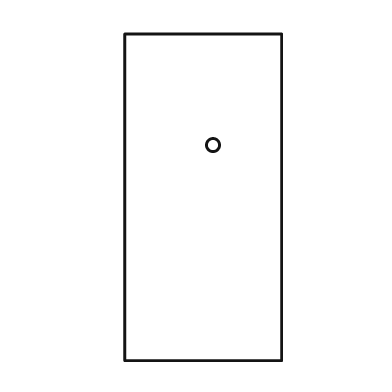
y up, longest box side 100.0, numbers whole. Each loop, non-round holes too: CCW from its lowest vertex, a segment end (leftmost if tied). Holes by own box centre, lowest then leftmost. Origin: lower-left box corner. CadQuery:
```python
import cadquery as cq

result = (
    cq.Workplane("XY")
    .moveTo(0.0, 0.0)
    .lineTo(48.0, 0.0)
    .lineTo(48.0, 100.0)
    .lineTo(0.0, 100.0)
    .close()
    .moveTo(27.0, 66.0)
    .circle(2.0)
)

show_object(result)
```